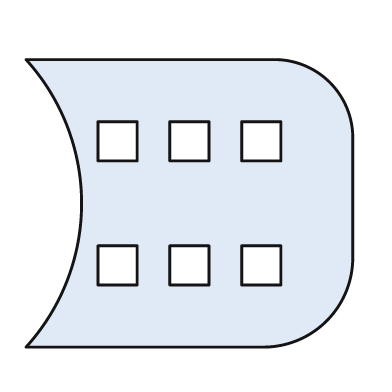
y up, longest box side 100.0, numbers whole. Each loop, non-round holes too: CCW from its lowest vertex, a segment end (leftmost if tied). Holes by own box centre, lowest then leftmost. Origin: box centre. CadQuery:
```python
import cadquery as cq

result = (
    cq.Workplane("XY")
    .moveTo(-50.0, -44.0)
    .lineTo(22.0, -44.0)
    .threePointArc((42.0, -36.0), (50.0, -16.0))
    .lineTo(50.0, 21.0)
    .threePointArc((43.0, 37.0), (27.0, 44.0))
    .lineTo(-50.0, 44.0)
    .threePointArc((-33.0, 0.0), (-50.0, -44.0))
    .close()
    .moveTo(-28.0, -25.0)
    .lineTo(-16.0, -25.0)
    .lineTo(-16.0, -13.0)
    .lineTo(-28.0, -13.0)
    .close()
    .moveTo(-6.0, -25.0)
    .lineTo(6.0, -25.0)
    .lineTo(6.0, -13.0)
    .lineTo(-6.0, -13.0)
    .close()
    .moveTo(16.0, -25.0)
    .lineTo(28.0, -25.0)
    .lineTo(28.0, -13.0)
    .lineTo(16.0, -13.0)
    .close()
    .moveTo(-28.0, 13.0)
    .lineTo(-16.0, 13.0)
    .lineTo(-16.0, 25.0)
    .lineTo(-28.0, 25.0)
    .close()
    .moveTo(-6.0, 13.0)
    .lineTo(6.0, 13.0)
    .lineTo(6.0, 25.0)
    .lineTo(-6.0, 25.0)
    .close()
    .moveTo(16.0, 13.0)
    .lineTo(28.0, 13.0)
    .lineTo(28.0, 25.0)
    .lineTo(16.0, 25.0)
    .close()
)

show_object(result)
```